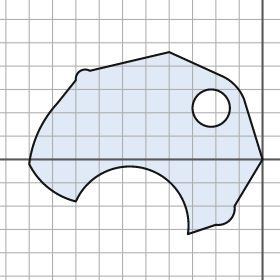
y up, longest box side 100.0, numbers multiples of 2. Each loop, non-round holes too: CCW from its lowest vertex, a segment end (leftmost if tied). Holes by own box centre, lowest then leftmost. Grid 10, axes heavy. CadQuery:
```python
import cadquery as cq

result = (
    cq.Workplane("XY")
    .moveTo(-32.0, -32.0)
    .lineTo(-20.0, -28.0)
    .threePointArc((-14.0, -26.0), (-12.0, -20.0))
    .lineTo(0.0, 0.0)
    .lineTo(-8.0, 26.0)
    .threePointArc((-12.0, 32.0), (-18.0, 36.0))
    .lineTo(-40.0, 46.0)
    .lineTo(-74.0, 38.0)
    .threePointArc((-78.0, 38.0), (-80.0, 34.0))
    .lineTo(-88.0, 24.0)
    .threePointArc((-96.0, 12.0), (-100.0, -2.0))
    .threePointArc((-92.0, -12.0), (-80.0, -18.0))
    .threePointArc((-50.0, -4.0), (-32.0, -32.0))
    .close()
    .moveTo(-22.0, 22.0)
    .circle(8.0)
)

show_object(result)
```